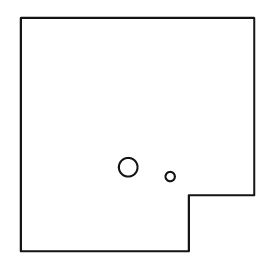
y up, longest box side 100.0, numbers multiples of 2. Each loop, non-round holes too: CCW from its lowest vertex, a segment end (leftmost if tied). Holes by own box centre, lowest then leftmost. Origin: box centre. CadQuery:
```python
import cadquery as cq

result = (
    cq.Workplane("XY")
    .moveTo(-50.0, -50.0)
    .lineTo(22.0, -50.0)
    .lineTo(22.0, -26.0)
    .lineTo(50.0, -26.0)
    .lineTo(50.0, 50.0)
    .lineTo(-50.0, 50.0)
    .close()
    .moveTo(14.0, -18.0)
    .circle(2.0)
    .moveTo(-4.0, -14.0)
    .circle(4.0)
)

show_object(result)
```